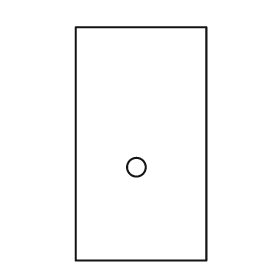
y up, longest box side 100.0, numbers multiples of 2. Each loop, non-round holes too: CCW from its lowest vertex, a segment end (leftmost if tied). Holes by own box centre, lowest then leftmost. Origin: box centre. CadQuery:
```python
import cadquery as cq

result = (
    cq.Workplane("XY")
    .moveTo(-28.0, -50.0)
    .lineTo(28.0, -50.0)
    .lineTo(28.0, 50.0)
    .lineTo(-28.0, 50.0)
    .close()
    .moveTo(-2.0, -10.0)
    .circle(4.0)
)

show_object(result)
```